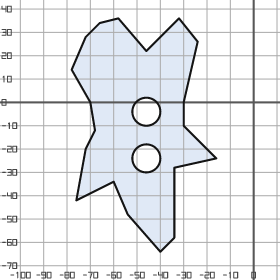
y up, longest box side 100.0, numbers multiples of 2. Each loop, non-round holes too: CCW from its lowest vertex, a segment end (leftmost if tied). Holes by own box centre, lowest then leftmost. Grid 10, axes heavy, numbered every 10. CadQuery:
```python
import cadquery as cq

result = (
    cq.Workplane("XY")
    .moveTo(-40.0, -64.0)
    .lineTo(-34.0, -58.0)
    .lineTo(-34.0, -28.0)
    .lineTo(-16.0, -24.0)
    .lineTo(-30.0, -10.0)
    .lineTo(-30.0, 0.0)
    .lineTo(-24.0, 26.0)
    .lineTo(-32.0, 36.0)
    .lineTo(-46.0, 22.0)
    .lineTo(-58.0, 36.0)
    .lineTo(-66.0, 34.0)
    .lineTo(-72.0, 28.0)
    .lineTo(-78.0, 14.0)
    .lineTo(-70.0, 0.0)
    .lineTo(-68.0, -12.0)
    .lineTo(-72.0, -20.0)
    .lineTo(-76.0, -42.0)
    .lineTo(-60.0, -34.0)
    .lineTo(-54.0, -48.0)
    .close()
    .moveTo(-46.0, -24.0)
    .circle(6.0)
    .moveTo(-46.0, -4.0)
    .circle(6.0)
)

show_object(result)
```